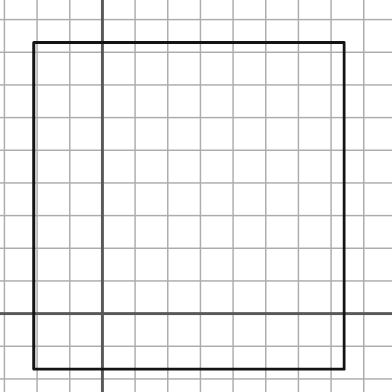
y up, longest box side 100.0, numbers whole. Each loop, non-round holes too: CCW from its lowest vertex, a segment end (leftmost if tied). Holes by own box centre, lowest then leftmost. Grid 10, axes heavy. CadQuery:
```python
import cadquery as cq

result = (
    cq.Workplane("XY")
    .moveTo(-21.0, -17.0)
    .lineTo(74.0, -17.0)
    .lineTo(74.0, 83.0)
    .lineTo(-21.0, 83.0)
    .close()
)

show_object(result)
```